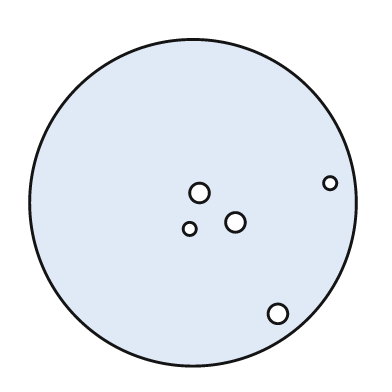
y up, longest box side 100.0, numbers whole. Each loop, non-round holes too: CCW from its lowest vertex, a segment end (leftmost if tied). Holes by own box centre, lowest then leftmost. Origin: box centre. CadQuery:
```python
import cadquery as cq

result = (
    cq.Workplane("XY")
    .moveTo(0.0, 0.0)
    .circle(50.0)
    .moveTo(26.0, -34.0)
    .circle(3.0)
    .moveTo(-1.0, -8.0)
    .circle(2.0)
    .moveTo(13.0, -6.0)
    .circle(3.0)
    .moveTo(2.0, 3.0)
    .circle(3.0)
    .moveTo(42.0, 6.0)
    .circle(2.0)
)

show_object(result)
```